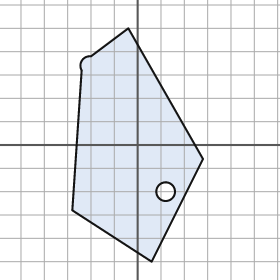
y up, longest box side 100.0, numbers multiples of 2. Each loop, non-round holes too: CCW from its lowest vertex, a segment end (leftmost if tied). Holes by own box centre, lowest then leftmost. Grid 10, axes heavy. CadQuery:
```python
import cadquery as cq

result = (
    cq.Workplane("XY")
    .moveTo(6.0, -50.0)
    .lineTo(28.0, -6.0)
    .lineTo(-4.0, 50.0)
    .lineTo(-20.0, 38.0)
    .threePointArc((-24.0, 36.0), (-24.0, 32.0))
    .lineTo(-28.0, -28.0)
    .close()
    .moveTo(12.0, -20.0)
    .circle(4.0)
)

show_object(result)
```